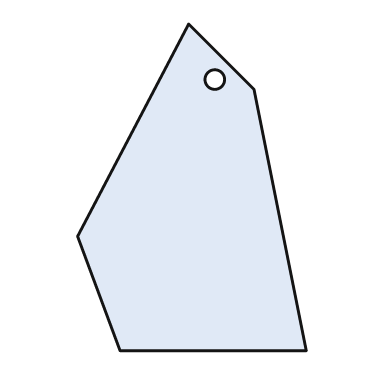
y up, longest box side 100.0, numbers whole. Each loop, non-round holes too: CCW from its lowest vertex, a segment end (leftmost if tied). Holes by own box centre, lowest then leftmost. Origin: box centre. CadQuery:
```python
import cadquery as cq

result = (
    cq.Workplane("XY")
    .moveTo(-22.0, -50.0)
    .lineTo(35.0, -50.0)
    .lineTo(19.0, 30.0)
    .lineTo(-1.0, 50.0)
    .lineTo(-35.0, -15.0)
    .close()
    .moveTo(7.0, 33.0)
    .circle(3.0)
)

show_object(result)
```